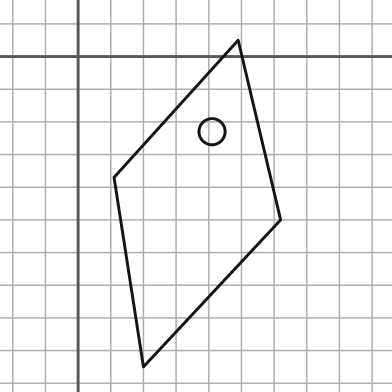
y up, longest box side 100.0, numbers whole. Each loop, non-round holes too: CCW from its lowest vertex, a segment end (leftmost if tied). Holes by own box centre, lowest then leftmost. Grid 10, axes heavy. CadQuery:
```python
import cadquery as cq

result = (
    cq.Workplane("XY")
    .moveTo(20.0, -95.0)
    .lineTo(62.0, -50.0)
    .lineTo(49.0, 5.0)
    .lineTo(11.0, -37.0)
    .close()
    .moveTo(41.0, -23.0)
    .circle(4.0)
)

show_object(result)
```